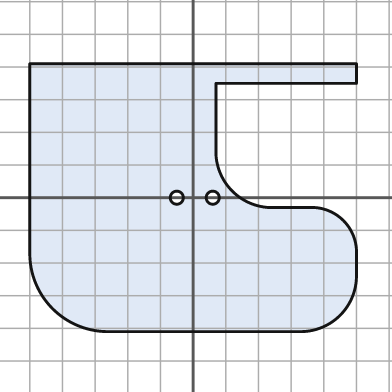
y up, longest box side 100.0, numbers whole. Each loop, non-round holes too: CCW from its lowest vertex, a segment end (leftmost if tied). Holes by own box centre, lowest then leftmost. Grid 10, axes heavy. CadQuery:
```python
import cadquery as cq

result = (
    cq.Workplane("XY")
    .moveTo(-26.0, -41.0)
    .lineTo(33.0, -41.0)
    .threePointArc((45.0, -36.0), (50.0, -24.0))
    .lineTo(50.0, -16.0)
    .threePointArc((46.0, -7.0), (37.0, -3.0))
    .lineTo(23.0, -3.0)
    .threePointArc((12.0, 2.0), (7.0, 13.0))
    .lineTo(7.0, 35.0)
    .lineTo(50.0, 35.0)
    .lineTo(50.0, 41.0)
    .lineTo(-50.0, 41.0)
    .lineTo(-50.0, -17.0)
    .threePointArc((-43.0, -34.0), (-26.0, -41.0))
    .close()
    .moveTo(-5.0, 0.0)
    .circle(2.0)
    .moveTo(6.0, 0.0)
    .circle(2.0)
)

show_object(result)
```